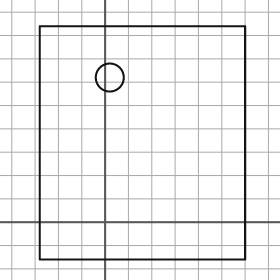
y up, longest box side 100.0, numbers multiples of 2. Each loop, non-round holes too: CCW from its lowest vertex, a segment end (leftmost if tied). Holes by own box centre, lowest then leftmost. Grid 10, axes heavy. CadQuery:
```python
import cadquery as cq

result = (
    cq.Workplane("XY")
    .moveTo(-28.0, -16.0)
    .lineTo(60.0, -16.0)
    .lineTo(60.0, 84.0)
    .lineTo(-28.0, 84.0)
    .close()
    .moveTo(2.0, 62.0)
    .circle(6.0)
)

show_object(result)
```